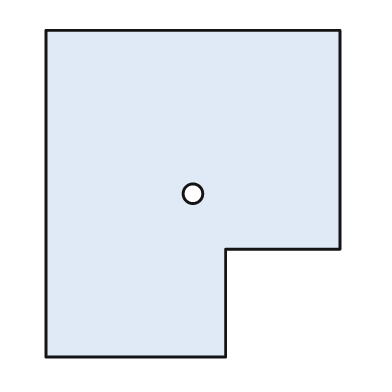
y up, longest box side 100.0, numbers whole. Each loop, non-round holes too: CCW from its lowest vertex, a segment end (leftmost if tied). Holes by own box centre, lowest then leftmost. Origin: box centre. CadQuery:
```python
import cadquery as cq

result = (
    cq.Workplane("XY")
    .moveTo(-45.0, -50.0)
    .lineTo(10.0, -50.0)
    .lineTo(10.0, -17.0)
    .lineTo(45.0, -17.0)
    .lineTo(45.0, 50.0)
    .lineTo(-45.0, 50.0)
    .close()
    .moveTo(0.0, 0.0)
    .circle(3.0)
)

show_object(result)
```